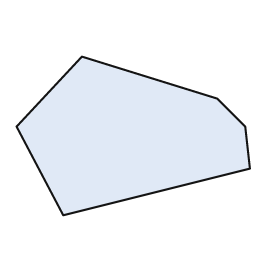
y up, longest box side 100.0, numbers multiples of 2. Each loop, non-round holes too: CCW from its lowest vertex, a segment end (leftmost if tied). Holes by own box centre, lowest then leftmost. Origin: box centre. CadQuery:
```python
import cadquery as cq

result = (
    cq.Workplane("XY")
    .moveTo(-30.0, -34.0)
    .lineTo(50.0, -14.0)
    .lineTo(48.0, 4.0)
    .lineTo(36.0, 16.0)
    .lineTo(-22.0, 34.0)
    .lineTo(-50.0, 4.0)
    .close()
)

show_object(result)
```